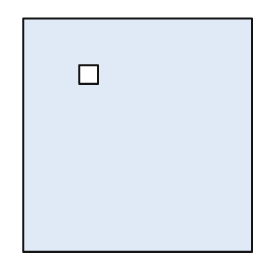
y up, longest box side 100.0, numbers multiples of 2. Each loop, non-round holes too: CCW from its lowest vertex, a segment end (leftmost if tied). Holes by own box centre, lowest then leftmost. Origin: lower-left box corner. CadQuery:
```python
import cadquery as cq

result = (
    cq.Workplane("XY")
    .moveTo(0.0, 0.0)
    .lineTo(98.0, 0.0)
    .lineTo(98.0, 100.0)
    .lineTo(0.0, 100.0)
    .close()
    .moveTo(24.0, 72.0)
    .lineTo(32.0, 72.0)
    .lineTo(32.0, 80.0)
    .lineTo(24.0, 80.0)
    .close()
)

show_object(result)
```